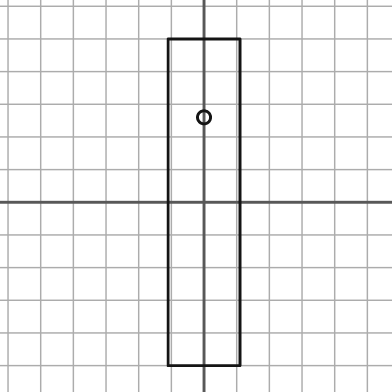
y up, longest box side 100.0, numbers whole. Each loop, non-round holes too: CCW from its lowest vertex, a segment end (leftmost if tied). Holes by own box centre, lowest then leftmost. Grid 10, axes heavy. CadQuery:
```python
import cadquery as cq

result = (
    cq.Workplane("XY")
    .moveTo(-11.0, -50.0)
    .lineTo(11.0, -50.0)
    .lineTo(11.0, 50.0)
    .lineTo(-11.0, 50.0)
    .close()
    .moveTo(0.0, 26.0)
    .circle(2.0)
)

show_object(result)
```